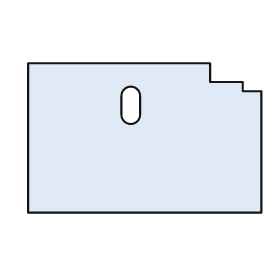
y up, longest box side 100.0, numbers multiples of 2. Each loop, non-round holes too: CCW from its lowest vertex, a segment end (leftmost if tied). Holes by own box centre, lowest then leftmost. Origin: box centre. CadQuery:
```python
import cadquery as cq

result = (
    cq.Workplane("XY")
    .moveTo(-50.0, -32.0)
    .lineTo(50.0, -32.0)
    .lineTo(50.0, 20.0)
    .lineTo(42.0, 20.0)
    .lineTo(42.0, 24.0)
    .lineTo(28.0, 24.0)
    .lineTo(28.0, 32.0)
    .lineTo(-50.0, 32.0)
    .close()
    .moveTo(-10.0, 10.0)
    .threePointArc((-6.0, 6.0), (-2.0, 10.0))
    .lineTo(-2.0, 18.0)
    .threePointArc((-6.0, 22.0), (-10.0, 18.0))
    .close()
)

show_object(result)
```